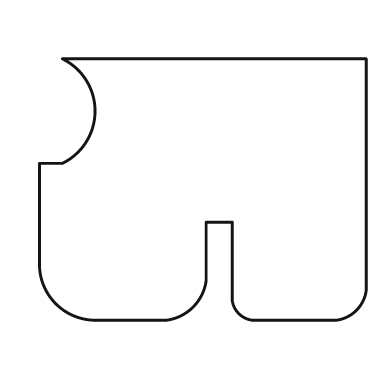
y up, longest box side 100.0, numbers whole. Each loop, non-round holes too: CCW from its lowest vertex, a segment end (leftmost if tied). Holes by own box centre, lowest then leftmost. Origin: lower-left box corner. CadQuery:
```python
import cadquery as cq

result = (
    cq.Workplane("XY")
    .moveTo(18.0, 0.0)
    .lineTo(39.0, 0.0)
    .threePointArc((47.0, 4.0), (51.0, 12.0))
    .lineTo(51.0, 30.0)
    .lineTo(59.0, 30.0)
    .lineTo(59.0, 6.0)
    .threePointArc((61.0, 2.0), (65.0, 0.0))
    .lineTo(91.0, 0.0)
    .threePointArc((97.0, 3.0), (100.0, 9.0))
    .lineTo(100.0, 80.0)
    .lineTo(7.0, 80.0)
    .threePointArc((17.0, 64.0), (7.0, 48.0))
    .lineTo(0.0, 48.0)
    .lineTo(0.0, 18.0)
    .threePointArc((5.0, 5.0), (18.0, 0.0))
    .close()
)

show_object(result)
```